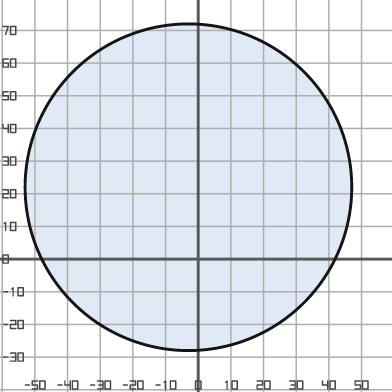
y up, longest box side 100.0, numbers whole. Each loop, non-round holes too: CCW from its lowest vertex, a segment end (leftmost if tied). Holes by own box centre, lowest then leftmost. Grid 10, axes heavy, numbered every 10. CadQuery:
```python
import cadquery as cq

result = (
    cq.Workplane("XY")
    .moveTo(-3.0, 22.0)
    .circle(50.0)
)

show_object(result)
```